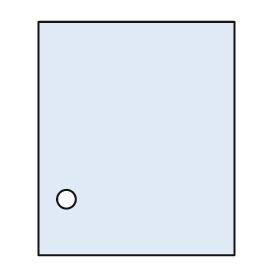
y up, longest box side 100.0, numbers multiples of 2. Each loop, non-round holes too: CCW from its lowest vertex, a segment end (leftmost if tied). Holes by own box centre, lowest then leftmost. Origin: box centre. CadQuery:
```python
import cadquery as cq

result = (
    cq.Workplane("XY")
    .moveTo(-42.0, -50.0)
    .lineTo(42.0, -50.0)
    .lineTo(42.0, 50.0)
    .lineTo(-42.0, 50.0)
    .close()
    .moveTo(-30.0, -26.0)
    .circle(4.0)
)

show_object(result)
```